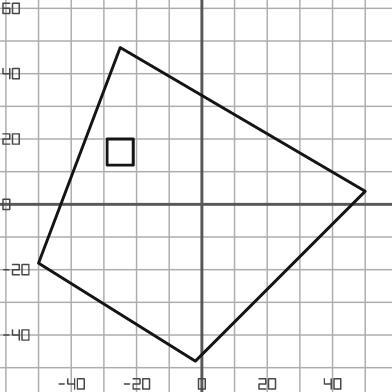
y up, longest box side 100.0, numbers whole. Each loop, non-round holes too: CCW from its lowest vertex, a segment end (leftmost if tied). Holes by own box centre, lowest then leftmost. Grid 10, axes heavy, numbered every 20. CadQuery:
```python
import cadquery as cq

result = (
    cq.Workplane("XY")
    .moveTo(-2.0, -48.0)
    .lineTo(50.0, 4.0)
    .lineTo(-25.0, 48.0)
    .lineTo(-50.0, -18.0)
    .close()
    .moveTo(-29.0, 12.0)
    .lineTo(-21.0, 12.0)
    .lineTo(-21.0, 20.0)
    .lineTo(-29.0, 20.0)
    .close()
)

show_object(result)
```